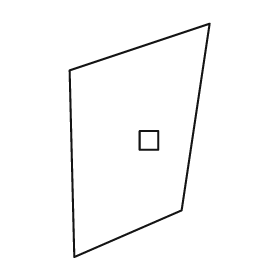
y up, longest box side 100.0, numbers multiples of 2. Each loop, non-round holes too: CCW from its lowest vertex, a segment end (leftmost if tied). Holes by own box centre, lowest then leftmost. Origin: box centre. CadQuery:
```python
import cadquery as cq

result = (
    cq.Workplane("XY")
    .moveTo(-28.0, -50.0)
    .lineTo(18.0, -30.0)
    .lineTo(30.0, 50.0)
    .lineTo(-30.0, 30.0)
    .close()
    .moveTo(0.0, -4.0)
    .lineTo(8.0, -4.0)
    .lineTo(8.0, 4.0)
    .lineTo(0.0, 4.0)
    .close()
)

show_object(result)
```